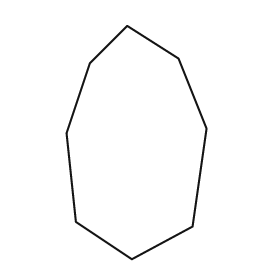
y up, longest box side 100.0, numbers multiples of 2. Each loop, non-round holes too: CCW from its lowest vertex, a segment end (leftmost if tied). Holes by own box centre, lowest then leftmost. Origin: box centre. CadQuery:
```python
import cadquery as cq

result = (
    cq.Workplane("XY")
    .moveTo(-2.0, -50.0)
    .lineTo(24.0, -36.0)
    .lineTo(30.0, 6.0)
    .lineTo(18.0, 36.0)
    .lineTo(-4.0, 50.0)
    .lineTo(-20.0, 34.0)
    .lineTo(-30.0, 4.0)
    .lineTo(-26.0, -34.0)
    .close()
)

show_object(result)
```